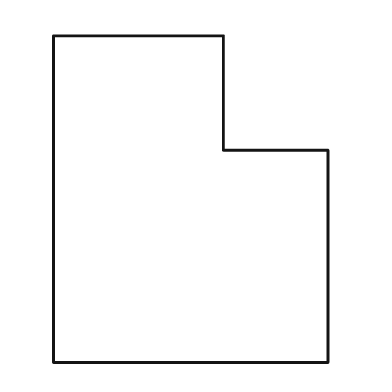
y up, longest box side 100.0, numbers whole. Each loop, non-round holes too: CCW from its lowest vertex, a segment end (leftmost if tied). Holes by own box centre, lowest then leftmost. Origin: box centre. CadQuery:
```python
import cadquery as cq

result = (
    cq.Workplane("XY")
    .moveTo(-42.0, -50.0)
    .lineTo(42.0, -50.0)
    .lineTo(42.0, 15.0)
    .lineTo(10.0, 15.0)
    .lineTo(10.0, 50.0)
    .lineTo(-42.0, 50.0)
    .close()
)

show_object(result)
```